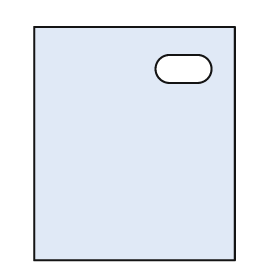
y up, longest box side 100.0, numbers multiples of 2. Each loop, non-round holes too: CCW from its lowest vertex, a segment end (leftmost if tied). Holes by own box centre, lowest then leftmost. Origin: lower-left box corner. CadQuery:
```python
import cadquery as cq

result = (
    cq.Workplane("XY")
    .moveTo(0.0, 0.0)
    .lineTo(86.0, 0.0)
    .lineTo(86.0, 100.0)
    .lineTo(0.0, 100.0)
    .close()
    .moveTo(58.0, 76.0)
    .lineTo(70.0, 76.0)
    .threePointArc((76.0, 82.0), (70.0, 88.0))
    .lineTo(58.0, 88.0)
    .threePointArc((52.0, 82.0), (58.0, 76.0))
    .close()
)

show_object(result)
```